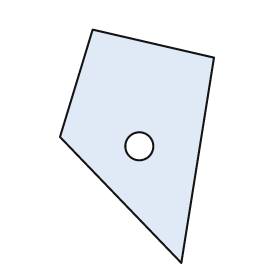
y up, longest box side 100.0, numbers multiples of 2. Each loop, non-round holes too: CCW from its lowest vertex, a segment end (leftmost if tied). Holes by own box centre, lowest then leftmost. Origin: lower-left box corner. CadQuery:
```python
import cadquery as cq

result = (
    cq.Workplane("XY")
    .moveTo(52.0, 0.0)
    .lineTo(66.0, 88.0)
    .lineTo(14.0, 100.0)
    .lineTo(0.0, 54.0)
    .close()
    .moveTo(34.0, 50.0)
    .circle(6.0)
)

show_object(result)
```